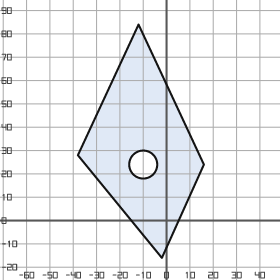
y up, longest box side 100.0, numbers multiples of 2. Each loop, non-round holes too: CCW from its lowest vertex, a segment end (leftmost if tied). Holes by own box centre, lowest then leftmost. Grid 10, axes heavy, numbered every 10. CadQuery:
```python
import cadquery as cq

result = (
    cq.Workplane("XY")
    .moveTo(-2.0, -16.0)
    .lineTo(16.0, 24.0)
    .lineTo(-12.0, 84.0)
    .lineTo(-38.0, 28.0)
    .close()
    .moveTo(-10.0, 24.0)
    .circle(6.0)
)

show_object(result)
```